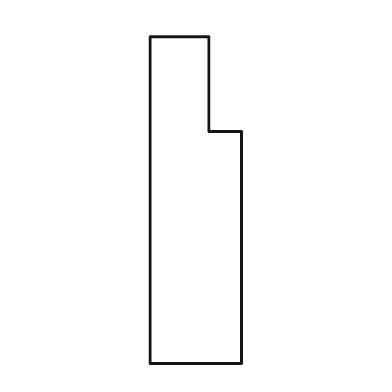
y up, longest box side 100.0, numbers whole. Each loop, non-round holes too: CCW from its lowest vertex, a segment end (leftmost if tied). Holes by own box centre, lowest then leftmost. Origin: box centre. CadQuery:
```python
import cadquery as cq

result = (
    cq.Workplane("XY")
    .moveTo(-14.0, -50.0)
    .lineTo(14.0, -50.0)
    .lineTo(14.0, 21.0)
    .lineTo(4.0, 21.0)
    .lineTo(4.0, 50.0)
    .lineTo(-14.0, 50.0)
    .close()
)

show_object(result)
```